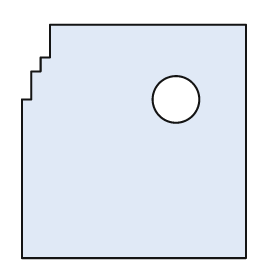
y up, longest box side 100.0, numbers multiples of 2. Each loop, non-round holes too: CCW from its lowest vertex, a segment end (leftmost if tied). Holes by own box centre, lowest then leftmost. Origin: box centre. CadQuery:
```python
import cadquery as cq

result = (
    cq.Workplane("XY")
    .moveTo(-48.0, -50.0)
    .lineTo(48.0, -50.0)
    .lineTo(48.0, 50.0)
    .lineTo(-36.0, 50.0)
    .lineTo(-36.0, 36.0)
    .lineTo(-40.0, 36.0)
    .lineTo(-40.0, 30.0)
    .lineTo(-44.0, 30.0)
    .lineTo(-44.0, 18.0)
    .lineTo(-48.0, 18.0)
    .close()
    .moveTo(18.0, 18.0)
    .circle(10.0)
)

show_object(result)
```